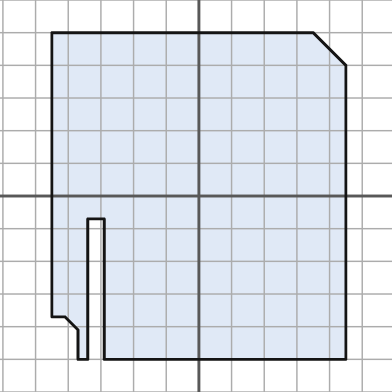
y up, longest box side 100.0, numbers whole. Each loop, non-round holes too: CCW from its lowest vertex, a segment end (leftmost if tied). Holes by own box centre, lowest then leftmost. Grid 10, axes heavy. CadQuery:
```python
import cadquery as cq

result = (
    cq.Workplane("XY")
    .moveTo(-37.0, -50.0)
    .lineTo(-34.0, -50.0)
    .lineTo(-34.0, -7.0)
    .lineTo(-29.0, -7.0)
    .lineTo(-29.0, -50.0)
    .lineTo(45.0, -50.0)
    .lineTo(45.0, 40.0)
    .lineTo(35.0, 50.0)
    .lineTo(-45.0, 50.0)
    .lineTo(-45.0, -37.0)
    .lineTo(-41.0, -37.0)
    .lineTo(-37.0, -41.0)
    .close()
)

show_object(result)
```